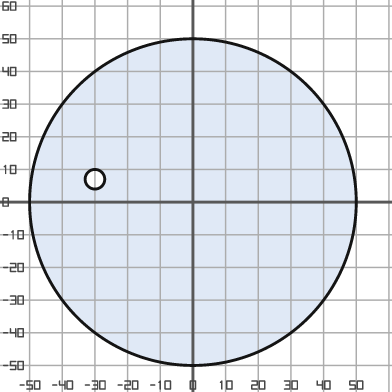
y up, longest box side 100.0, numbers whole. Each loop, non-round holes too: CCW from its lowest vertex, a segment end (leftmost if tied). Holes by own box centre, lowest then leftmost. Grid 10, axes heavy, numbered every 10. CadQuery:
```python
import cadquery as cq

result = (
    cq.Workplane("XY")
    .moveTo(0.0, 0.0)
    .circle(50.0)
    .moveTo(-30.0, 7.0)
    .circle(3.0)
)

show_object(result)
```